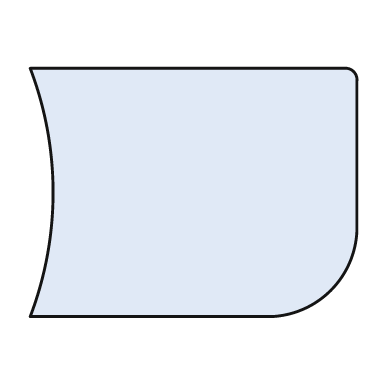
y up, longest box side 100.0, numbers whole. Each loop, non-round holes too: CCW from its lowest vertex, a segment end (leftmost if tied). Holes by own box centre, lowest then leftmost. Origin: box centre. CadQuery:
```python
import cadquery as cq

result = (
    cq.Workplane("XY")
    .moveTo(-50.0, -38.0)
    .lineTo(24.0, -38.0)
    .threePointArc((42.0, -30.0), (50.0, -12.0))
    .lineTo(50.0, 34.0)
    .threePointArc((49.0, 37.0), (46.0, 38.0))
    .lineTo(-50.0, 38.0)
    .threePointArc((-43.0, 0.0), (-50.0, -38.0))
    .close()
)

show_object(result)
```